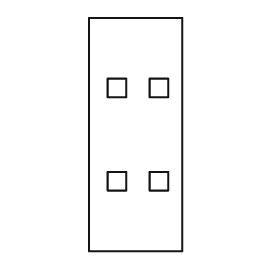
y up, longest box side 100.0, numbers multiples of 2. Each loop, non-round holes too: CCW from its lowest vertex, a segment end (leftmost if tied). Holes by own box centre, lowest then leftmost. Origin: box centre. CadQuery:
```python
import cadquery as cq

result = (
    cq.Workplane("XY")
    .moveTo(-20.0, -50.0)
    .lineTo(20.0, -50.0)
    .lineTo(20.0, 50.0)
    .lineTo(-20.0, 50.0)
    .close()
    .moveTo(-12.0, -24.0)
    .lineTo(-4.0, -24.0)
    .lineTo(-4.0, -16.0)
    .lineTo(-12.0, -16.0)
    .close()
    .moveTo(6.0, -24.0)
    .lineTo(14.0, -24.0)
    .lineTo(14.0, -16.0)
    .lineTo(6.0, -16.0)
    .close()
    .moveTo(-12.0, 16.0)
    .lineTo(-4.0, 16.0)
    .lineTo(-4.0, 24.0)
    .lineTo(-12.0, 24.0)
    .close()
    .moveTo(6.0, 16.0)
    .lineTo(14.0, 16.0)
    .lineTo(14.0, 24.0)
    .lineTo(6.0, 24.0)
    .close()
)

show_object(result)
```